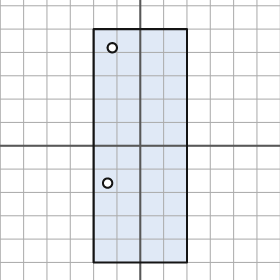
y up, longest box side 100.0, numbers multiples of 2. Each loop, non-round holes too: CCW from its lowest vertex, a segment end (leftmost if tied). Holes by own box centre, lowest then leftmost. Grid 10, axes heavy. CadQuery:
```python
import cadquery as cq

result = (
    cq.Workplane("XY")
    .moveTo(-20.0, -50.0)
    .lineTo(20.0, -50.0)
    .lineTo(20.0, 50.0)
    .lineTo(-20.0, 50.0)
    .close()
    .moveTo(-14.0, -16.0)
    .circle(2.0)
    .moveTo(-12.0, 42.0)
    .circle(2.0)
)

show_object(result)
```